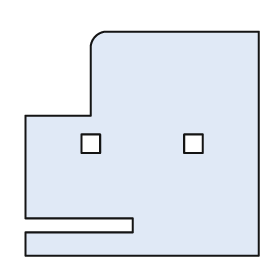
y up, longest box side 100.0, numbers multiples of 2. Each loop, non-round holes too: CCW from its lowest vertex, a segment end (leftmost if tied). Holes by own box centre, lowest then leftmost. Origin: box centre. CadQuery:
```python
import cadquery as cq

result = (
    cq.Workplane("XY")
    .moveTo(-50.0, -48.0)
    .lineTo(50.0, -48.0)
    .lineTo(50.0, 48.0)
    .lineTo(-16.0, 48.0)
    .threePointArc((-20.0, 46.0), (-22.0, 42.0))
    .lineTo(-22.0, 12.0)
    .lineTo(-50.0, 12.0)
    .lineTo(-50.0, -32.0)
    .lineTo(-4.0, -32.0)
    .lineTo(-4.0, -38.0)
    .lineTo(-50.0, -38.0)
    .close()
    .moveTo(-26.0, -4.0)
    .lineTo(-18.0, -4.0)
    .lineTo(-18.0, 4.0)
    .lineTo(-26.0, 4.0)
    .close()
    .moveTo(18.0, -4.0)
    .lineTo(26.0, -4.0)
    .lineTo(26.0, 4.0)
    .lineTo(18.0, 4.0)
    .close()
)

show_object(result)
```